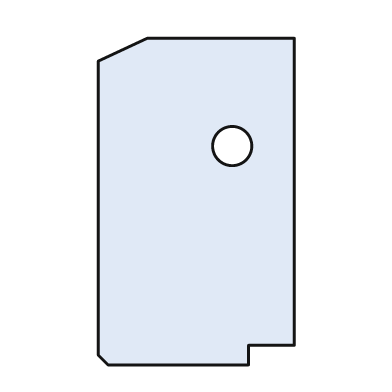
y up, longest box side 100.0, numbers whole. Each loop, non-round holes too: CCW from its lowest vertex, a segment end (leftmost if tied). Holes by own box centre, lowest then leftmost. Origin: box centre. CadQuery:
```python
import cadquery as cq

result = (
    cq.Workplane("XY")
    .moveTo(-27.0, -50.0)
    .lineTo(16.0, -50.0)
    .lineTo(16.0, -44.0)
    .lineTo(30.0, -44.0)
    .lineTo(30.0, 50.0)
    .lineTo(-15.0, 50.0)
    .lineTo(-30.0, 43.0)
    .lineTo(-30.0, -47.0)
    .close()
    .moveTo(11.0, 17.0)
    .circle(6.0)
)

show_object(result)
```